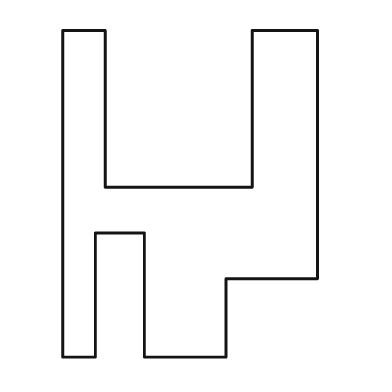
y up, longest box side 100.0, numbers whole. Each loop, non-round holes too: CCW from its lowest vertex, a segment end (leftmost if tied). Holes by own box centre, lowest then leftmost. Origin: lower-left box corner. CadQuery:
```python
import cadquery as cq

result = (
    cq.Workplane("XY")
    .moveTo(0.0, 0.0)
    .lineTo(10.0, 0.0)
    .lineTo(10.0, 38.0)
    .lineTo(25.0, 38.0)
    .lineTo(25.0, 0.0)
    .lineTo(50.0, 0.0)
    .lineTo(50.0, 24.0)
    .lineTo(78.0, 24.0)
    .lineTo(78.0, 100.0)
    .lineTo(58.0, 100.0)
    .lineTo(58.0, 52.0)
    .lineTo(13.0, 52.0)
    .lineTo(13.0, 100.0)
    .lineTo(0.0, 100.0)
    .close()
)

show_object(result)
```